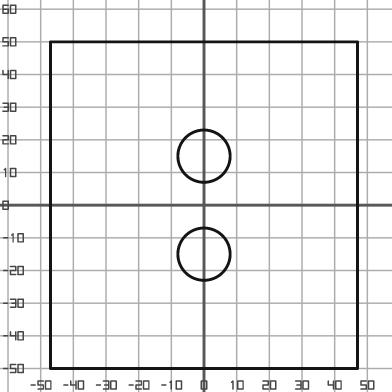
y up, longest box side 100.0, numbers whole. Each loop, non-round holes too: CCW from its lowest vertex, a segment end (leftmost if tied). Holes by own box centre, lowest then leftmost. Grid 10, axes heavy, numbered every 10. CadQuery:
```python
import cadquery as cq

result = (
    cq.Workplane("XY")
    .moveTo(-47.0, -50.0)
    .lineTo(47.0, -50.0)
    .lineTo(47.0, 50.0)
    .lineTo(-47.0, 50.0)
    .close()
    .moveTo(0.0, -15.0)
    .circle(8.0)
    .moveTo(0.0, 15.0)
    .circle(8.0)
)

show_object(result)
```